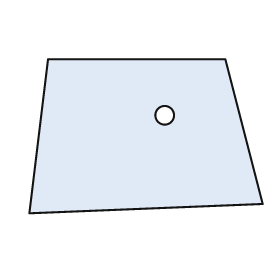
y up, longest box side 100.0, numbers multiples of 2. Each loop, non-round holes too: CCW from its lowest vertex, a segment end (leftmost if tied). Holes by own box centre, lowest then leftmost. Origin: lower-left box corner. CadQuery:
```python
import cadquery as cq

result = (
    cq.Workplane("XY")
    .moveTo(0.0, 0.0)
    .lineTo(100.0, 4.0)
    .lineTo(84.0, 66.0)
    .lineTo(8.0, 66.0)
    .close()
    .moveTo(58.0, 42.0)
    .circle(4.0)
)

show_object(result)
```